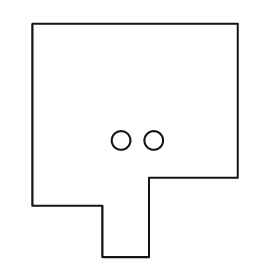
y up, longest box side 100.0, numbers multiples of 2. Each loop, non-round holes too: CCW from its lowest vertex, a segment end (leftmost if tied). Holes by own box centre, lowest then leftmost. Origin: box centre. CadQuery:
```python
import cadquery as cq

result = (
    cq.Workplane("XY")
    .moveTo(-14.0, -50.0)
    .lineTo(6.0, -50.0)
    .lineTo(6.0, -16.0)
    .lineTo(44.0, -16.0)
    .lineTo(44.0, 50.0)
    .lineTo(-44.0, 50.0)
    .lineTo(-44.0, -28.0)
    .lineTo(-14.0, -28.0)
    .close()
    .moveTo(-6.0, 0.0)
    .circle(4.0)
    .moveTo(8.0, 0.0)
    .circle(4.0)
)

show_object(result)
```